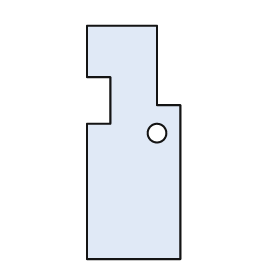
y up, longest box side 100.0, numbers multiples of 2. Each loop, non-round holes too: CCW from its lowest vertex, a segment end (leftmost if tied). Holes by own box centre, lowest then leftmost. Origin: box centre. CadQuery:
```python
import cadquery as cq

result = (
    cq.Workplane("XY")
    .moveTo(-20.0, -50.0)
    .lineTo(20.0, -50.0)
    .lineTo(20.0, 16.0)
    .lineTo(10.0, 16.0)
    .lineTo(10.0, 50.0)
    .lineTo(-20.0, 50.0)
    .lineTo(-20.0, 28.0)
    .lineTo(-10.0, 28.0)
    .lineTo(-10.0, 8.0)
    .lineTo(-20.0, 8.0)
    .close()
    .moveTo(10.0, 4.0)
    .circle(4.0)
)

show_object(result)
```